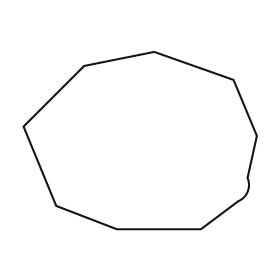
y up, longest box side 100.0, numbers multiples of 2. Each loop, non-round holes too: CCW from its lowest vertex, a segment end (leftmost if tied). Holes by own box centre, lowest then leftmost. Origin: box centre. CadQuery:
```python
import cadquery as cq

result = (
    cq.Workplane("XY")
    .moveTo(-10.0, -38.0)
    .lineTo(26.0, -38.0)
    .lineTo(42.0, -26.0)
    .threePointArc((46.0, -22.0), (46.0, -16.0))
    .lineTo(50.0, 2.0)
    .lineTo(40.0, 26.0)
    .lineTo(6.0, 38.0)
    .lineTo(-24.0, 32.0)
    .lineTo(-50.0, 6.0)
    .lineTo(-36.0, -28.0)
    .close()
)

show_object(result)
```